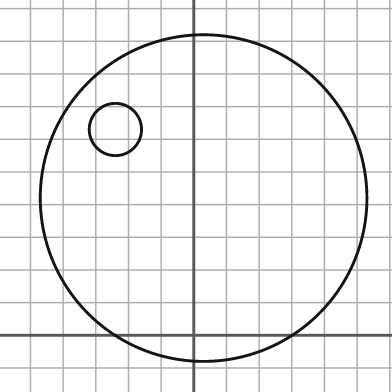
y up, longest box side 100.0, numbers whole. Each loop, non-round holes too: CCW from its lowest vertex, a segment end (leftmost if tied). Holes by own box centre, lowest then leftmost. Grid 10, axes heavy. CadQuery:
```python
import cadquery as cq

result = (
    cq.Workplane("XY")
    .moveTo(3.0, 42.0)
    .circle(50.0)
    .moveTo(-24.0, 63.0)
    .circle(8.0)
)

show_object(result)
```